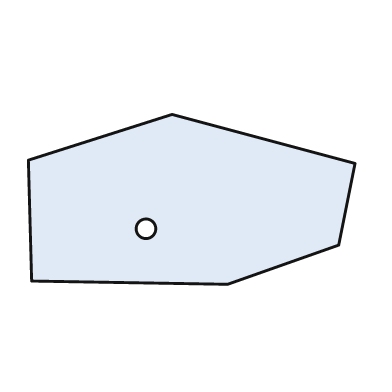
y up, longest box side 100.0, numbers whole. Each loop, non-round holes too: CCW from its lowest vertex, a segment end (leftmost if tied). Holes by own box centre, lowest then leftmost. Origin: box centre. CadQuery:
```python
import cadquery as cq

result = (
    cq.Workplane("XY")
    .moveTo(11.0, -26.0)
    .lineTo(45.0, -14.0)
    .lineTo(50.0, 11.0)
    .lineTo(-6.0, 26.0)
    .lineTo(-50.0, 12.0)
    .lineTo(-49.0, -25.0)
    .close()
    .moveTo(-14.0, -9.0)
    .circle(3.0)
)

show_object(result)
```